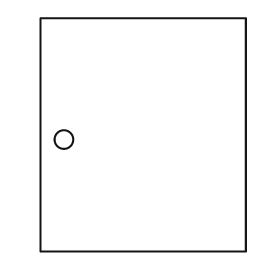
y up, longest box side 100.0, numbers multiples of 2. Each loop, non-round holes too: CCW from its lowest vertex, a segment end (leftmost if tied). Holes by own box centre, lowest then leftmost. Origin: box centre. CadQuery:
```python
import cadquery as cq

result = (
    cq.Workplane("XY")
    .moveTo(-44.0, -50.0)
    .lineTo(44.0, -50.0)
    .lineTo(44.0, 50.0)
    .lineTo(-44.0, 50.0)
    .close()
    .moveTo(-34.0, -2.0)
    .circle(4.0)
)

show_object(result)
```